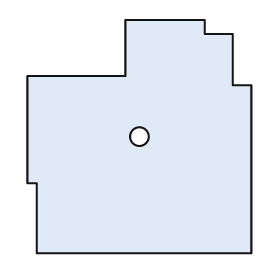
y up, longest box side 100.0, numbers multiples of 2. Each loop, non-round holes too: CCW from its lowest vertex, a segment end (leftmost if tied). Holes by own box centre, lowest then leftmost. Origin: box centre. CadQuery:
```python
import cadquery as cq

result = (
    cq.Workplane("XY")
    .moveTo(-44.0, -50.0)
    .lineTo(48.0, -50.0)
    .lineTo(48.0, 22.0)
    .lineTo(40.0, 22.0)
    .lineTo(40.0, 44.0)
    .lineTo(28.0, 44.0)
    .lineTo(28.0, 50.0)
    .lineTo(-6.0, 50.0)
    .lineTo(-6.0, 26.0)
    .lineTo(-48.0, 26.0)
    .lineTo(-48.0, -20.0)
    .lineTo(-44.0, -20.0)
    .close()
    .moveTo(0.0, 0.0)
    .circle(4.0)
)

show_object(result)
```